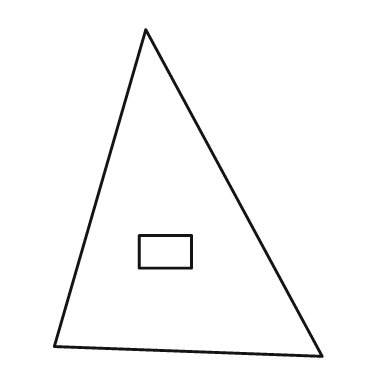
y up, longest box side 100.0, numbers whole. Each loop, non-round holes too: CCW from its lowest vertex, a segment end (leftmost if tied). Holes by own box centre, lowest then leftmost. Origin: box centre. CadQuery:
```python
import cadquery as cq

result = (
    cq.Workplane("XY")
    .moveTo(41.0, -50.0)
    .lineTo(-13.0, 50.0)
    .lineTo(-41.0, -47.0)
    .close()
    .moveTo(-15.0, -23.0)
    .lineTo(1.0, -23.0)
    .lineTo(1.0, -13.0)
    .lineTo(-15.0, -13.0)
    .close()
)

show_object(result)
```